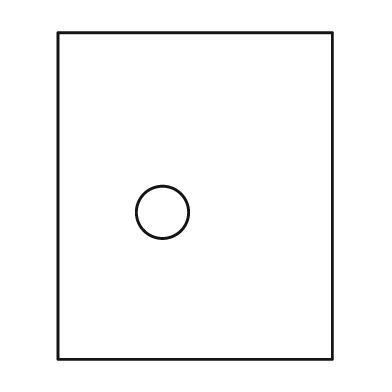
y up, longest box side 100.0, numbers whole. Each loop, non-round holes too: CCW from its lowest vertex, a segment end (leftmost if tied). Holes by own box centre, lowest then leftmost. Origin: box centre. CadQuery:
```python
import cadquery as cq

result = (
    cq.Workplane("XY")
    .moveTo(-42.0, -50.0)
    .lineTo(42.0, -50.0)
    .lineTo(42.0, 50.0)
    .lineTo(-42.0, 50.0)
    .close()
    .moveTo(-10.0, -5.0)
    .circle(8.0)
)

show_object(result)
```